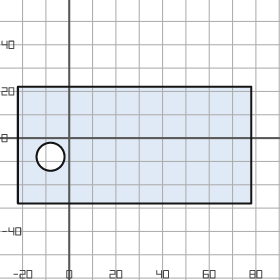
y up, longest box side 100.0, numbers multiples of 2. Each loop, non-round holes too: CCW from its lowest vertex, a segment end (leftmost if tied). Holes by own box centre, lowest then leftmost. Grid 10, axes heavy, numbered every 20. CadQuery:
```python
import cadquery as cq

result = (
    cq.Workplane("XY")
    .moveTo(-22.0, -28.0)
    .lineTo(78.0, -28.0)
    .lineTo(78.0, 22.0)
    .lineTo(-22.0, 22.0)
    .close()
    .moveTo(-8.0, -8.0)
    .circle(6.0)
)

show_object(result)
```